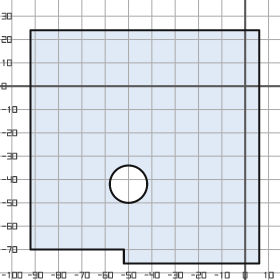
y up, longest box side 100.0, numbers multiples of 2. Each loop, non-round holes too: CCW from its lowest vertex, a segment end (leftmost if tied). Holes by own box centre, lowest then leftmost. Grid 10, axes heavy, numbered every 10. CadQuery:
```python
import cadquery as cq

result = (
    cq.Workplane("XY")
    .moveTo(-52.0, -76.0)
    .lineTo(6.0, -76.0)
    .lineTo(6.0, 24.0)
    .lineTo(-92.0, 24.0)
    .lineTo(-92.0, -70.0)
    .lineTo(-52.0, -70.0)
    .close()
    .moveTo(-50.0, -42.0)
    .circle(8.0)
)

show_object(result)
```